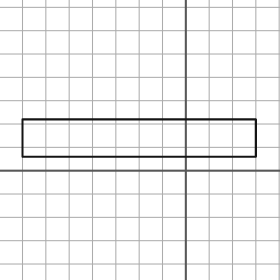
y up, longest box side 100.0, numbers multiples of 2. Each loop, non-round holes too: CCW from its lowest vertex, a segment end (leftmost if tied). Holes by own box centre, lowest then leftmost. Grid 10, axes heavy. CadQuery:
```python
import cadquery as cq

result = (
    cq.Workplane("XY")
    .moveTo(-70.0, 6.0)
    .lineTo(30.0, 6.0)
    .lineTo(30.0, 22.0)
    .lineTo(-70.0, 22.0)
    .close()
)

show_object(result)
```